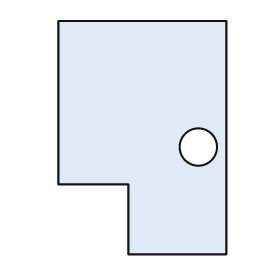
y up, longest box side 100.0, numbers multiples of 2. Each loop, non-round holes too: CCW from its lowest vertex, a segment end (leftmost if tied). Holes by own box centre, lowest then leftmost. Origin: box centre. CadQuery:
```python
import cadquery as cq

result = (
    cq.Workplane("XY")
    .moveTo(-6.0, -50.0)
    .lineTo(36.0, -50.0)
    .lineTo(36.0, 50.0)
    .lineTo(-36.0, 50.0)
    .lineTo(-36.0, -20.0)
    .lineTo(-6.0, -20.0)
    .close()
    .moveTo(24.0, -4.0)
    .circle(8.0)
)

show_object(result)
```